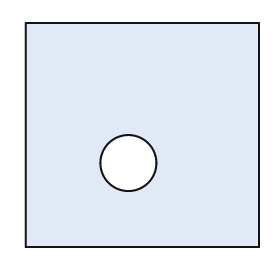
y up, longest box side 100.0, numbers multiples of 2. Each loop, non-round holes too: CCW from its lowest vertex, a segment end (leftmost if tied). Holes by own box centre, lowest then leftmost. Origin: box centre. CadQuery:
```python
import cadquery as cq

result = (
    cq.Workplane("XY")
    .moveTo(-50.0, -48.0)
    .lineTo(50.0, -48.0)
    .lineTo(50.0, 48.0)
    .lineTo(-50.0, 48.0)
    .close()
    .moveTo(-6.0, -12.0)
    .circle(12.0)
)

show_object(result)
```